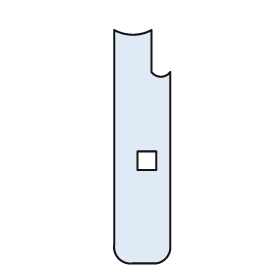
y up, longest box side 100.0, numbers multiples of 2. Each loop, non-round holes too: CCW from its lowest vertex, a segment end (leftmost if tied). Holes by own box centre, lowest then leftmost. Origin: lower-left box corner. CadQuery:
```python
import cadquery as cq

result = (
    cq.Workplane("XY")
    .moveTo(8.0, 0.0)
    .lineTo(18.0, 0.0)
    .threePointArc((22.0, 2.0), (24.0, 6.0))
    .lineTo(24.0, 82.0)
    .threePointArc((20.0, 80.0), (16.0, 82.0))
    .lineTo(16.0, 100.0)
    .threePointArc((8.0, 98.0), (0.0, 100.0))
    .lineTo(0.0, 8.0)
    .threePointArc((2.0, 2.0), (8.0, 0.0))
    .close()
    .moveTo(10.0, 40.0)
    .lineTo(18.0, 40.0)
    .lineTo(18.0, 48.0)
    .lineTo(10.0, 48.0)
    .close()
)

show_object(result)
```